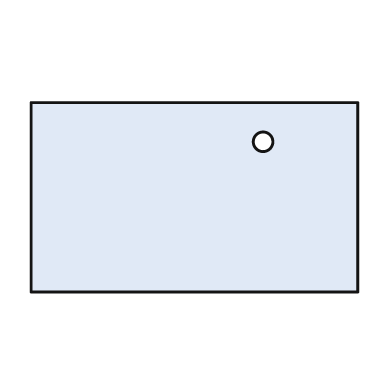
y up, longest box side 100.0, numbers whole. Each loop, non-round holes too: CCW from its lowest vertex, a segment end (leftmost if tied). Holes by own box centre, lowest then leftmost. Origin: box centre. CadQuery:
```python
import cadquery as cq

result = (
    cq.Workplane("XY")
    .moveTo(-50.0, -29.0)
    .lineTo(50.0, -29.0)
    .lineTo(50.0, 29.0)
    .lineTo(-50.0, 29.0)
    .close()
    .moveTo(21.0, 17.0)
    .circle(3.0)
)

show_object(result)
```